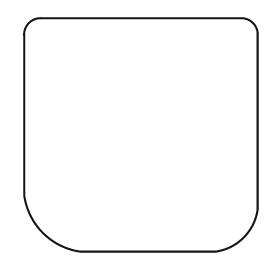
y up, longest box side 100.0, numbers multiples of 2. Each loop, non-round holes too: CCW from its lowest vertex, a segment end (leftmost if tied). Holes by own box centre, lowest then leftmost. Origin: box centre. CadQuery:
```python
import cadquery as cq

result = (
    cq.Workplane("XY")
    .moveTo(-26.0, -50.0)
    .lineTo(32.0, -50.0)
    .threePointArc((44.0, -44.0), (50.0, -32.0))
    .lineTo(50.0, 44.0)
    .threePointArc((48.0, 48.0), (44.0, 50.0))
    .lineTo(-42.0, 50.0)
    .threePointArc((-48.0, 48.0), (-50.0, 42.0))
    .lineTo(-50.0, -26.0)
    .threePointArc((-42.0, -42.0), (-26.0, -50.0))
    .close()
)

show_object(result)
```